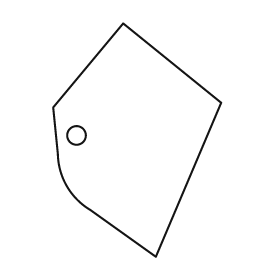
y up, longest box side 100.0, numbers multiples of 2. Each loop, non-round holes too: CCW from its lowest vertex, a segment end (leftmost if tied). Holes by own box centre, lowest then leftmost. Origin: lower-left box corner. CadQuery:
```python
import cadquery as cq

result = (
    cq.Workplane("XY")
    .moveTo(44.0, 0.0)
    .lineTo(72.0, 66.0)
    .lineTo(30.0, 100.0)
    .lineTo(0.0, 64.0)
    .lineTo(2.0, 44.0)
    .threePointArc((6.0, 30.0), (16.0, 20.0))
    .close()
    .moveTo(10.0, 52.0)
    .circle(4.0)
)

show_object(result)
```